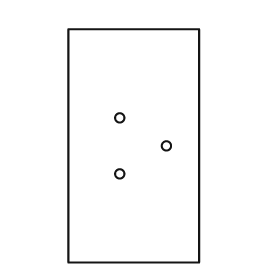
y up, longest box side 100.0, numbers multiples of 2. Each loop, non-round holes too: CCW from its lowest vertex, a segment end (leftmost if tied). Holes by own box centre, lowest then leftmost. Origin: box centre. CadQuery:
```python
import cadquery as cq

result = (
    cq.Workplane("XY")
    .moveTo(-28.0, -50.0)
    .lineTo(28.0, -50.0)
    .lineTo(28.0, 50.0)
    .lineTo(-28.0, 50.0)
    .close()
    .moveTo(-6.0, -12.0)
    .circle(2.0)
    .moveTo(14.0, 0.0)
    .circle(2.0)
    .moveTo(-6.0, 12.0)
    .circle(2.0)
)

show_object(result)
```